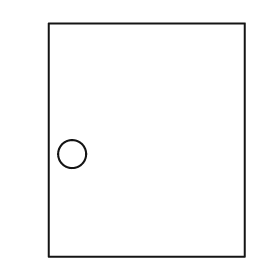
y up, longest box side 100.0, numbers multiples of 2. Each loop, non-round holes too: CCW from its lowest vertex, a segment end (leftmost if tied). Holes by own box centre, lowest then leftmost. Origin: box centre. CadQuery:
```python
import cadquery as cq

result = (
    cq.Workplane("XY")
    .moveTo(-42.0, -50.0)
    .lineTo(42.0, -50.0)
    .lineTo(42.0, 50.0)
    .lineTo(-42.0, 50.0)
    .close()
    .moveTo(-32.0, -6.0)
    .circle(6.0)
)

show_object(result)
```